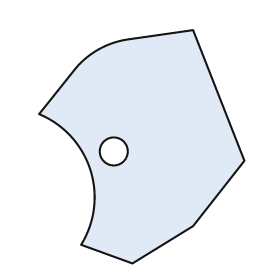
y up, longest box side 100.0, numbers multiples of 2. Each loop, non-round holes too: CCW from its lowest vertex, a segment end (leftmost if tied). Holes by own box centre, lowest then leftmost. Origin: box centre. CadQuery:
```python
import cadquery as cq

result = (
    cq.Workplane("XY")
    .moveTo(-4.0, -50.0)
    .lineTo(22.0, -34.0)
    .lineTo(44.0, -6.0)
    .lineTo(22.0, 50.0)
    .lineTo(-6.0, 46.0)
    .threePointArc((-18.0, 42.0), (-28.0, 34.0))
    .lineTo(-44.0, 14.0)
    .threePointArc((-22.0, -10.0), (-26.0, -42.0))
    .close()
    .moveTo(-12.0, -2.0)
    .circle(6.0)
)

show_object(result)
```